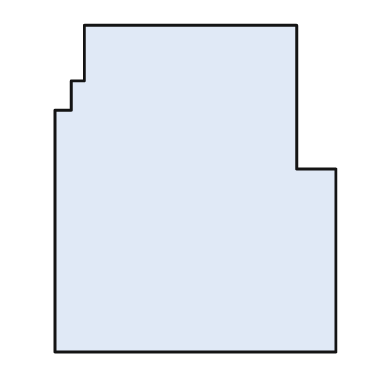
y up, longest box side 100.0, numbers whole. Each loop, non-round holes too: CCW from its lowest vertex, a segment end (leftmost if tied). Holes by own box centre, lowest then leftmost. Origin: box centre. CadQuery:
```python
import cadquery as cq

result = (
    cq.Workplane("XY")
    .moveTo(-43.0, -50.0)
    .lineTo(43.0, -50.0)
    .lineTo(43.0, 6.0)
    .lineTo(31.0, 6.0)
    .lineTo(31.0, 50.0)
    .lineTo(-34.0, 50.0)
    .lineTo(-34.0, 33.0)
    .lineTo(-38.0, 33.0)
    .lineTo(-38.0, 24.0)
    .lineTo(-43.0, 24.0)
    .close()
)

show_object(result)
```